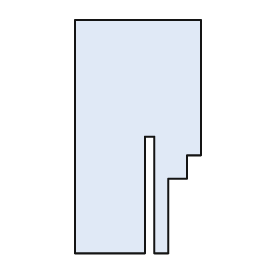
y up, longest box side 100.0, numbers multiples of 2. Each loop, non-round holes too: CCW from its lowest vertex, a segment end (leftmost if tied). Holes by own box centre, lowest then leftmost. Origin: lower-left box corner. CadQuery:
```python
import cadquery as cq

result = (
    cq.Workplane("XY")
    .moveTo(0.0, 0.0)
    .lineTo(30.0, 0.0)
    .lineTo(30.0, 50.0)
    .lineTo(34.0, 50.0)
    .lineTo(34.0, 0.0)
    .lineTo(40.0, 0.0)
    .lineTo(40.0, 32.0)
    .lineTo(48.0, 32.0)
    .lineTo(48.0, 42.0)
    .lineTo(54.0, 42.0)
    .lineTo(54.0, 100.0)
    .lineTo(0.0, 100.0)
    .close()
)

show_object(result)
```